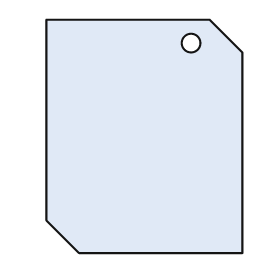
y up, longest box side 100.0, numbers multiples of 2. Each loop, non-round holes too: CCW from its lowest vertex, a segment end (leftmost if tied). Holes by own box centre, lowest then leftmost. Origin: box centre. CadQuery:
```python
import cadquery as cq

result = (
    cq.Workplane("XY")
    .moveTo(-28.0, -50.0)
    .lineTo(42.0, -50.0)
    .lineTo(42.0, 36.0)
    .lineTo(28.0, 50.0)
    .lineTo(-42.0, 50.0)
    .lineTo(-42.0, -36.0)
    .close()
    .moveTo(20.0, 40.0)
    .circle(4.0)
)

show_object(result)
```